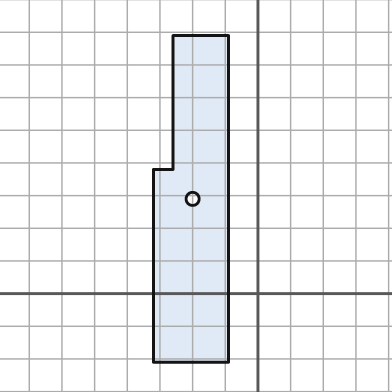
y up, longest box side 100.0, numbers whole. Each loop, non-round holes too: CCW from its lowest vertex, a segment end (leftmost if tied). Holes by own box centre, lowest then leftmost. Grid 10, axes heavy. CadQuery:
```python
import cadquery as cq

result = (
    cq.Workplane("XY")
    .moveTo(-32.0, -21.0)
    .lineTo(-9.0, -21.0)
    .lineTo(-9.0, 79.0)
    .lineTo(-26.0, 79.0)
    .lineTo(-26.0, 38.0)
    .lineTo(-32.0, 38.0)
    .close()
    .moveTo(-20.0, 29.0)
    .circle(2.0)
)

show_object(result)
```